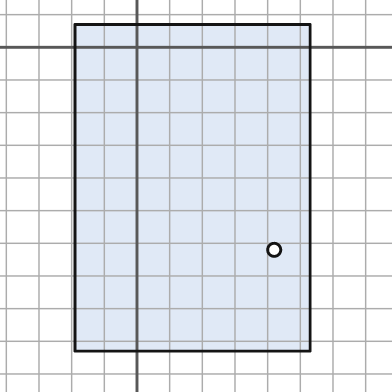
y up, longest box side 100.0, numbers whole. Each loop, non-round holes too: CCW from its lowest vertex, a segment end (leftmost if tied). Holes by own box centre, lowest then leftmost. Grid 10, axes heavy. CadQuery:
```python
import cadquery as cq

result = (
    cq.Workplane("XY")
    .moveTo(-19.0, -93.0)
    .lineTo(53.0, -93.0)
    .lineTo(53.0, 7.0)
    .lineTo(-19.0, 7.0)
    .close()
    .moveTo(42.0, -62.0)
    .circle(2.0)
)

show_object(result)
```